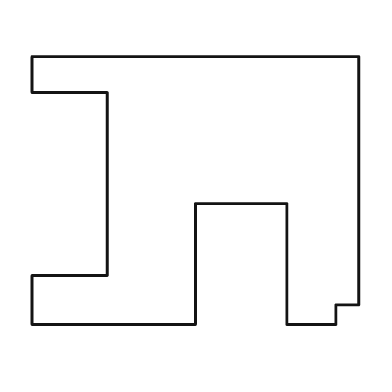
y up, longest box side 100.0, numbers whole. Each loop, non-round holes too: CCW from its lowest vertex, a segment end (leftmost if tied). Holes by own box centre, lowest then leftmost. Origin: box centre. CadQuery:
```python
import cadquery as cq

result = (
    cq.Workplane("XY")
    .moveTo(-50.0, -41.0)
    .lineTo(0.0, -41.0)
    .lineTo(0.0, -4.0)
    .lineTo(28.0, -4.0)
    .lineTo(28.0, -41.0)
    .lineTo(43.0, -41.0)
    .lineTo(43.0, -35.0)
    .lineTo(50.0, -35.0)
    .lineTo(50.0, 41.0)
    .lineTo(-50.0, 41.0)
    .lineTo(-50.0, 30.0)
    .lineTo(-27.0, 30.0)
    .lineTo(-27.0, -26.0)
    .lineTo(-50.0, -26.0)
    .close()
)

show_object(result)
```